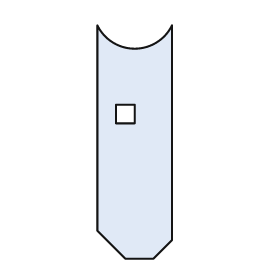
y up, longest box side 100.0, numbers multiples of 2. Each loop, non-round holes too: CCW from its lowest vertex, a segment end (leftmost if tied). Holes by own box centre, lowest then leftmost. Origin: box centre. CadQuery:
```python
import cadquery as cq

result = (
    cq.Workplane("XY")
    .moveTo(-4.0, -50.0)
    .lineTo(8.0, -50.0)
    .lineTo(16.0, -42.0)
    .lineTo(16.0, 50.0)
    .threePointArc((0.0, 40.0), (-16.0, 50.0))
    .lineTo(-16.0, -38.0)
    .close()
    .moveTo(-8.0, 8.0)
    .lineTo(0.0, 8.0)
    .lineTo(0.0, 16.0)
    .lineTo(-8.0, 16.0)
    .close()
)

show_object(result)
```